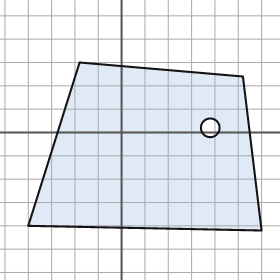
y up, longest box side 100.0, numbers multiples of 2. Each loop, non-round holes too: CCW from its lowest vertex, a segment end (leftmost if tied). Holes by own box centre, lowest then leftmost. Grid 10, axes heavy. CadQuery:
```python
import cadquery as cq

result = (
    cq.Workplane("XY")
    .moveTo(60.0, -42.0)
    .lineTo(52.0, 24.0)
    .lineTo(-18.0, 30.0)
    .lineTo(-40.0, -40.0)
    .close()
    .moveTo(38.0, 2.0)
    .circle(4.0)
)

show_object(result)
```